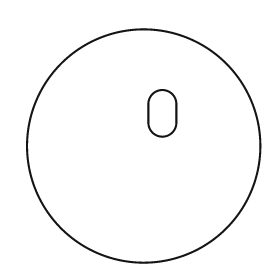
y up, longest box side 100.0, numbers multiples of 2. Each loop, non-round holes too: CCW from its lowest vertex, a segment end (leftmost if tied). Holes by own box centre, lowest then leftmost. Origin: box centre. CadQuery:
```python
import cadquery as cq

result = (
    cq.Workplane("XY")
    .moveTo(0.0, 0.0)
    .circle(50.0)
    .moveTo(2.0, 10.0)
    .threePointArc((8.0, 4.0), (14.0, 10.0))
    .lineTo(14.0, 18.0)
    .threePointArc((8.0, 24.0), (2.0, 18.0))
    .close()
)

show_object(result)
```